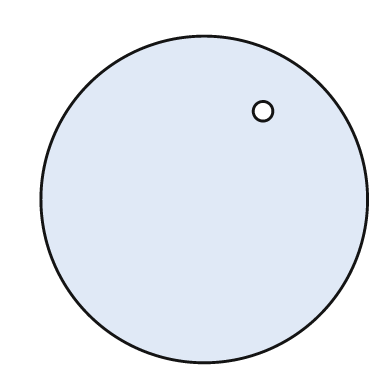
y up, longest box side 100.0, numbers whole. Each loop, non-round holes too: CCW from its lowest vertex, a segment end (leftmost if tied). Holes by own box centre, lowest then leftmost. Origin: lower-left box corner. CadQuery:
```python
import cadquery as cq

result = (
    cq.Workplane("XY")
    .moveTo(50.0, 50.0)
    .circle(50.0)
    .moveTo(68.0, 77.0)
    .circle(3.0)
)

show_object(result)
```